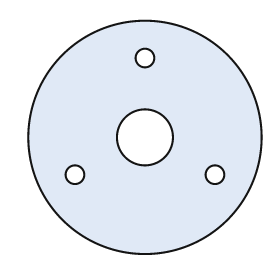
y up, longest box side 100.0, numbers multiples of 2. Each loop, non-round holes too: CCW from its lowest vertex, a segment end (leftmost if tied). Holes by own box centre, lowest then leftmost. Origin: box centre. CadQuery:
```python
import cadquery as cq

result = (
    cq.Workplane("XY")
    .moveTo(0.0, 0.0)
    .circle(50.0)
    .moveTo(-30.0, -16.0)
    .circle(4.0)
    .moveTo(30.0, -16.0)
    .circle(4.0)
    .moveTo(0.0, 0.0)
    .circle(12.0)
    .moveTo(0.0, 34.0)
    .circle(4.0)
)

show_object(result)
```